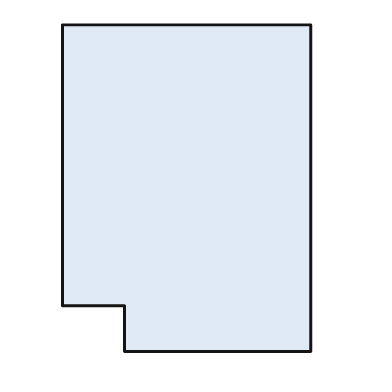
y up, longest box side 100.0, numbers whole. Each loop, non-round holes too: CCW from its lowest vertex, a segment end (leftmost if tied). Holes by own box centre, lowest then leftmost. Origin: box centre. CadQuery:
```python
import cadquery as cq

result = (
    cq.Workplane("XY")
    .moveTo(-19.0, -50.0)
    .lineTo(38.0, -50.0)
    .lineTo(38.0, 50.0)
    .lineTo(-38.0, 50.0)
    .lineTo(-38.0, -36.0)
    .lineTo(-19.0, -36.0)
    .close()
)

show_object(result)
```